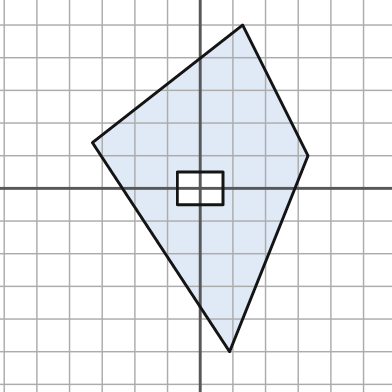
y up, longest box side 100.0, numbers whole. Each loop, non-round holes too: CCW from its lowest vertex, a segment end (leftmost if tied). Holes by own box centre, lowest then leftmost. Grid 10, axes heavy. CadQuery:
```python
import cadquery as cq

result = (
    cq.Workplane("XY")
    .moveTo(9.0, -50.0)
    .lineTo(33.0, 10.0)
    .lineTo(13.0, 50.0)
    .lineTo(-33.0, 14.0)
    .close()
    .moveTo(-7.0, -5.0)
    .lineTo(7.0, -5.0)
    .lineTo(7.0, 5.0)
    .lineTo(-7.0, 5.0)
    .close()
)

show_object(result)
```